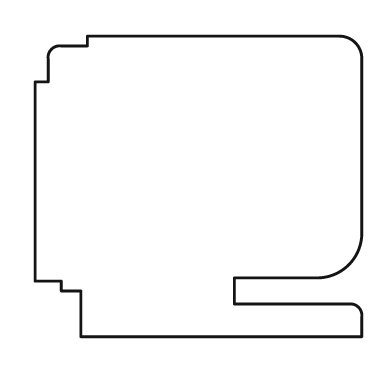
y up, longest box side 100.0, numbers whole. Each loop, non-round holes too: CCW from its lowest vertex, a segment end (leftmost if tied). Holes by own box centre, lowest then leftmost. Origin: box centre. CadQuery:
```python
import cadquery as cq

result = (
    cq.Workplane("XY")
    .moveTo(-36.0, -46.0)
    .lineTo(50.0, -46.0)
    .lineTo(50.0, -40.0)
    .threePointArc((49.0, -37.0), (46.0, -36.0))
    .lineTo(11.0, -36.0)
    .lineTo(11.0, -28.0)
    .lineTo(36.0, -28.0)
    .threePointArc((46.0, -24.0), (50.0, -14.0))
    .lineTo(50.0, 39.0)
    .threePointArc((48.0, 44.0), (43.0, 46.0))
    .lineTo(-34.0, 46.0)
    .lineTo(-34.0, 43.0)
    .lineTo(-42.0, 43.0)
    .threePointArc((-45.0, 42.0), (-46.0, 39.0))
    .lineTo(-46.0, 32.0)
    .lineTo(-50.0, 32.0)
    .lineTo(-50.0, -29.0)
    .lineTo(-42.0, -29.0)
    .lineTo(-42.0, -32.0)
    .lineTo(-36.0, -32.0)
    .close()
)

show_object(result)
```